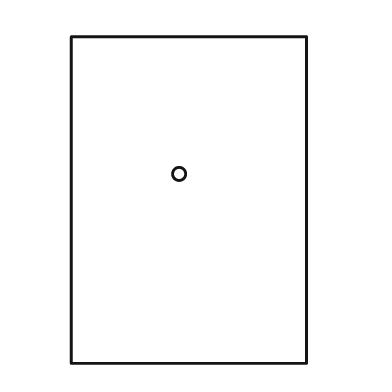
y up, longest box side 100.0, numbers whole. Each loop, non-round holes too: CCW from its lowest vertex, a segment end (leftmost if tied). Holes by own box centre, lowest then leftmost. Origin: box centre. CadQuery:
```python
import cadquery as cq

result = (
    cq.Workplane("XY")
    .moveTo(-36.0, -50.0)
    .lineTo(36.0, -50.0)
    .lineTo(36.0, 50.0)
    .lineTo(-36.0, 50.0)
    .close()
    .moveTo(-3.0, 8.0)
    .circle(2.0)
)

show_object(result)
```